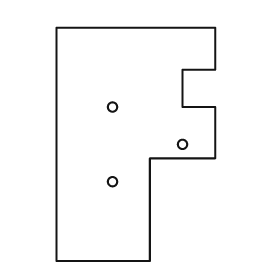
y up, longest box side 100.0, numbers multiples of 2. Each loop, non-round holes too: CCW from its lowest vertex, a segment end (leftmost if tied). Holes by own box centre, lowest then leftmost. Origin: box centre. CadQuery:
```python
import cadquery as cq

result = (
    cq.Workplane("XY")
    .moveTo(-34.0, -50.0)
    .lineTo(6.0, -50.0)
    .lineTo(6.0, -6.0)
    .lineTo(34.0, -6.0)
    .lineTo(34.0, 16.0)
    .lineTo(20.0, 16.0)
    .lineTo(20.0, 32.0)
    .lineTo(34.0, 32.0)
    .lineTo(34.0, 50.0)
    .lineTo(-34.0, 50.0)
    .close()
    .moveTo(-10.0, -16.0)
    .circle(2.0)
    .moveTo(20.0, 0.0)
    .circle(2.0)
    .moveTo(-10.0, 16.0)
    .circle(2.0)
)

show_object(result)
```